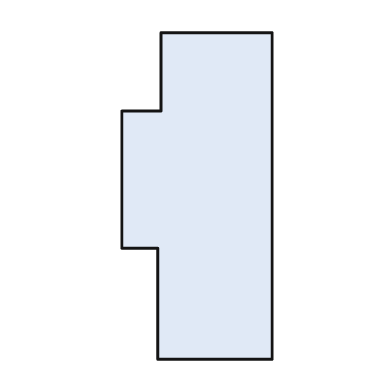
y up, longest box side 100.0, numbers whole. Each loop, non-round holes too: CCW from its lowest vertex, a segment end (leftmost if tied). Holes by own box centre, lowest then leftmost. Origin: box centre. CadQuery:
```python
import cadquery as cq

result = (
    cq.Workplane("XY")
    .moveTo(-12.0, -50.0)
    .lineTo(23.0, -50.0)
    .lineTo(23.0, 50.0)
    .lineTo(-11.0, 50.0)
    .lineTo(-11.0, 26.0)
    .lineTo(-23.0, 26.0)
    .lineTo(-23.0, -16.0)
    .lineTo(-12.0, -16.0)
    .close()
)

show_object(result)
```